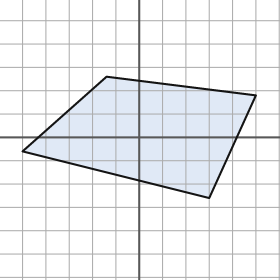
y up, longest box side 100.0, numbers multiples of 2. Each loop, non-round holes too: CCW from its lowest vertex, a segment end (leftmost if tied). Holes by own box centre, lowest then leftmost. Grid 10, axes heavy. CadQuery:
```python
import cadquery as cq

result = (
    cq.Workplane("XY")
    .moveTo(30.0, -26.0)
    .lineTo(50.0, 18.0)
    .lineTo(-14.0, 26.0)
    .lineTo(-50.0, -6.0)
    .close()
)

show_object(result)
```